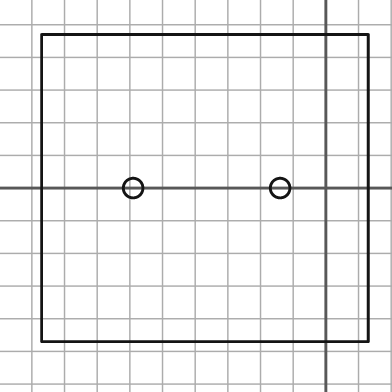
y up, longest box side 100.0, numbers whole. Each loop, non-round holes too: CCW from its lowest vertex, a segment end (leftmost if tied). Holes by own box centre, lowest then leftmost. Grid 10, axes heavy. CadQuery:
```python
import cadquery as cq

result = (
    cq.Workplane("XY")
    .moveTo(-87.0, -47.0)
    .lineTo(13.0, -47.0)
    .lineTo(13.0, 47.0)
    .lineTo(-87.0, 47.0)
    .close()
    .moveTo(-59.0, 0.0)
    .circle(3.0)
    .moveTo(-14.0, 0.0)
    .circle(3.0)
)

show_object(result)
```